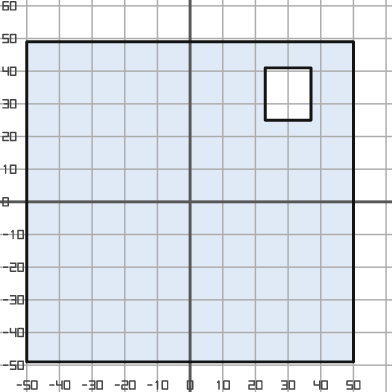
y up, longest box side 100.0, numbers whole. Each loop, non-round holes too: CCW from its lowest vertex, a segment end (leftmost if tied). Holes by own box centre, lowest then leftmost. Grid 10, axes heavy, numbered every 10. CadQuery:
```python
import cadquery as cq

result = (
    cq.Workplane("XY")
    .moveTo(-50.0, -49.0)
    .lineTo(50.0, -49.0)
    .lineTo(50.0, 49.0)
    .lineTo(-50.0, 49.0)
    .close()
    .moveTo(23.0, 25.0)
    .lineTo(37.0, 25.0)
    .lineTo(37.0, 41.0)
    .lineTo(23.0, 41.0)
    .close()
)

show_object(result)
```